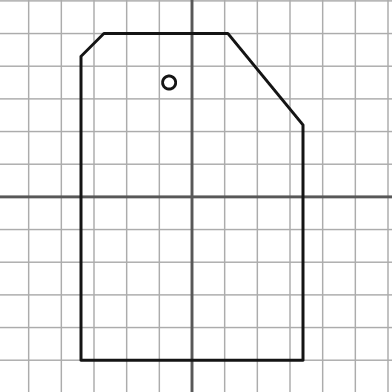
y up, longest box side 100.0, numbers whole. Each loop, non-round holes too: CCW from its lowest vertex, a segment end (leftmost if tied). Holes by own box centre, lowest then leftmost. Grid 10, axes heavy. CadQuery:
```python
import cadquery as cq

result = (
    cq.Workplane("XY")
    .moveTo(-34.0, -50.0)
    .lineTo(34.0, -50.0)
    .lineTo(34.0, 22.0)
    .lineTo(11.0, 50.0)
    .lineTo(-27.0, 50.0)
    .lineTo(-34.0, 43.0)
    .close()
    .moveTo(-7.0, 35.0)
    .circle(2.0)
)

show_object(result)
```